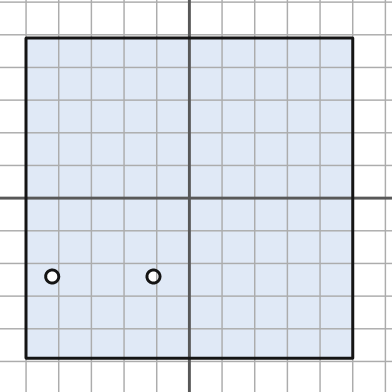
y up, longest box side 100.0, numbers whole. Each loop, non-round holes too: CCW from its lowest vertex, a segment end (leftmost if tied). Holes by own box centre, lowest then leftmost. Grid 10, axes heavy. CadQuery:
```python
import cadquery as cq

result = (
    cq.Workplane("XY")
    .moveTo(-50.0, -49.0)
    .lineTo(50.0, -49.0)
    .lineTo(50.0, 49.0)
    .lineTo(-50.0, 49.0)
    .close()
    .moveTo(-42.0, -24.0)
    .circle(2.0)
    .moveTo(-11.0, -24.0)
    .circle(2.0)
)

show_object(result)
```